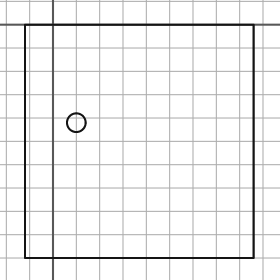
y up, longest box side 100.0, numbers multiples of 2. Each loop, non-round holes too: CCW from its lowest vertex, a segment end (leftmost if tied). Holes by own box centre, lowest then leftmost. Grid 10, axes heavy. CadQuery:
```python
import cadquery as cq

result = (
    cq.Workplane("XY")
    .moveTo(-12.0, -100.0)
    .lineTo(86.0, -100.0)
    .lineTo(86.0, 0.0)
    .lineTo(-12.0, 0.0)
    .close()
    .moveTo(10.0, -42.0)
    .circle(4.0)
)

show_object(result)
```